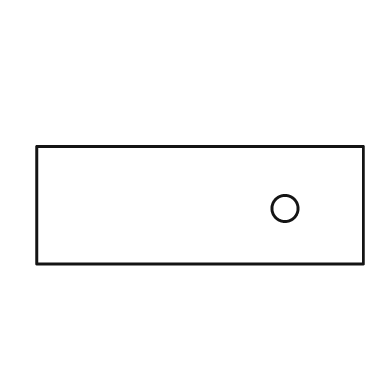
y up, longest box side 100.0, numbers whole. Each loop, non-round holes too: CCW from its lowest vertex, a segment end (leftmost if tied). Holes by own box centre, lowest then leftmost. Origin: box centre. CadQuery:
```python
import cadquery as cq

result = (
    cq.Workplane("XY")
    .moveTo(-50.0, -18.0)
    .lineTo(50.0, -18.0)
    .lineTo(50.0, 18.0)
    .lineTo(-50.0, 18.0)
    .close()
    .moveTo(26.0, -1.0)
    .circle(4.0)
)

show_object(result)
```